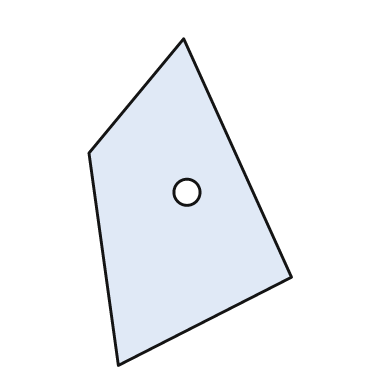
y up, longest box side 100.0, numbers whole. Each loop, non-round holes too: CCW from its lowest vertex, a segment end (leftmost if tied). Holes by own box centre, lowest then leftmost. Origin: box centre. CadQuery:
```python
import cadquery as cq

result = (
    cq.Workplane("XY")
    .moveTo(-22.0, -50.0)
    .lineTo(31.0, -23.0)
    .lineTo(-2.0, 50.0)
    .lineTo(-31.0, 15.0)
    .close()
    .moveTo(-1.0, 3.0)
    .circle(4.0)
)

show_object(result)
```